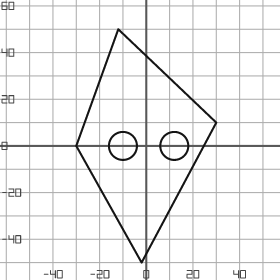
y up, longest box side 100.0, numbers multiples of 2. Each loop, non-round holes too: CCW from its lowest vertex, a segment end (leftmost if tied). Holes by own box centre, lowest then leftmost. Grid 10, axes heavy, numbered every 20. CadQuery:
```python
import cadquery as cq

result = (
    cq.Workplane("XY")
    .moveTo(-2.0, -50.0)
    .lineTo(30.0, 10.0)
    .lineTo(-12.0, 50.0)
    .lineTo(-30.0, 0.0)
    .close()
    .moveTo(-10.0, 0.0)
    .circle(6.0)
    .moveTo(12.0, 0.0)
    .circle(6.0)
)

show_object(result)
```